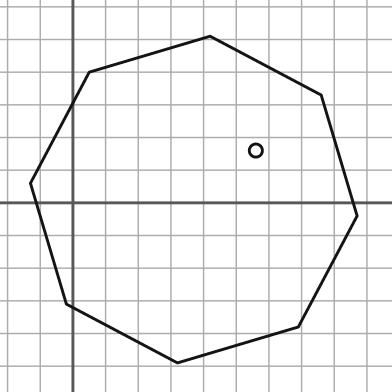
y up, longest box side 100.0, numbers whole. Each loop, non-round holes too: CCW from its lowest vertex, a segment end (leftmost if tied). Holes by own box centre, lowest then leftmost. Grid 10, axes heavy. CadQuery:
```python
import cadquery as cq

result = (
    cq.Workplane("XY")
    .moveTo(32.0, -49.0)
    .lineTo(69.0, -38.0)
    .lineTo(87.0, -4.0)
    .lineTo(76.0, 33.0)
    .lineTo(42.0, 51.0)
    .lineTo(5.0, 40.0)
    .lineTo(-13.0, 6.0)
    .lineTo(-2.0, -31.0)
    .close()
    .moveTo(56.0, 16.0)
    .circle(2.0)
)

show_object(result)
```